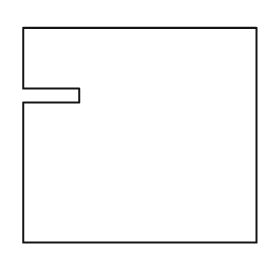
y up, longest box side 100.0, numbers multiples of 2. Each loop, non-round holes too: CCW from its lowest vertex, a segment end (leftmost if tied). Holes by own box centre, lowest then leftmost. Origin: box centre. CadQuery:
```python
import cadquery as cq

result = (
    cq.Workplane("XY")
    .moveTo(-50.0, -46.0)
    .lineTo(50.0, -46.0)
    .lineTo(50.0, 46.0)
    .lineTo(-50.0, 46.0)
    .lineTo(-50.0, 20.0)
    .lineTo(-26.0, 20.0)
    .lineTo(-26.0, 14.0)
    .lineTo(-50.0, 14.0)
    .close()
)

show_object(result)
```